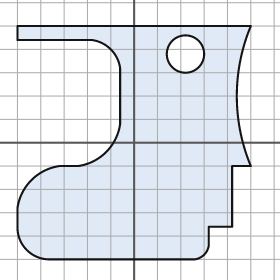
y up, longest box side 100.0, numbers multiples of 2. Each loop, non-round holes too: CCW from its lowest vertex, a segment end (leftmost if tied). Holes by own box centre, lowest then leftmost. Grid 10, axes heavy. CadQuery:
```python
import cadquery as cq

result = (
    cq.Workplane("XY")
    .moveTo(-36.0, -50.0)
    .lineTo(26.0, -50.0)
    .threePointArc((30.0, -48.0), (32.0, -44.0))
    .lineTo(32.0, -36.0)
    .lineTo(42.0, -36.0)
    .lineTo(42.0, -10.0)
    .lineTo(50.0, -10.0)
    .threePointArc((44.0, 20.0), (50.0, 50.0))
    .lineTo(-50.0, 50.0)
    .lineTo(-50.0, 44.0)
    .lineTo(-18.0, 44.0)
    .threePointArc((-10.0, 40.0), (-6.0, 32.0))
    .lineTo(-6.0, 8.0)
    .threePointArc((-12.0, -4.0), (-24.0, -10.0))
    .lineTo(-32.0, -10.0)
    .threePointArc((-44.0, -16.0), (-50.0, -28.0))
    .lineTo(-50.0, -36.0)
    .threePointArc((-46.0, -46.0), (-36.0, -50.0))
    .close()
    .moveTo(22.0, 38.0)
    .circle(8.0)
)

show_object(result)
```